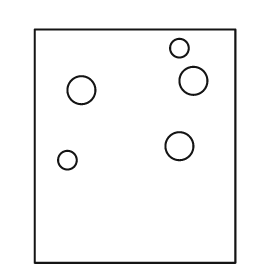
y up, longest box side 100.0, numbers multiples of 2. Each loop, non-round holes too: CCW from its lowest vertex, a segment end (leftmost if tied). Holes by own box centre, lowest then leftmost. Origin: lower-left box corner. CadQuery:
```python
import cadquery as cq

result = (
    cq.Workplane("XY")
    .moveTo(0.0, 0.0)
    .lineTo(86.0, 0.0)
    .lineTo(86.0, 100.0)
    .lineTo(0.0, 100.0)
    .close()
    .moveTo(14.0, 44.0)
    .circle(4.0)
    .moveTo(62.0, 50.0)
    .circle(6.0)
    .moveTo(20.0, 74.0)
    .circle(6.0)
    .moveTo(68.0, 78.0)
    .circle(6.0)
    .moveTo(62.0, 92.0)
    .circle(4.0)
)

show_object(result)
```